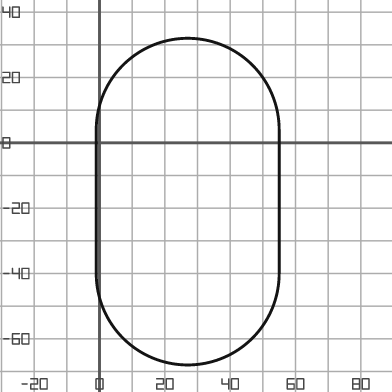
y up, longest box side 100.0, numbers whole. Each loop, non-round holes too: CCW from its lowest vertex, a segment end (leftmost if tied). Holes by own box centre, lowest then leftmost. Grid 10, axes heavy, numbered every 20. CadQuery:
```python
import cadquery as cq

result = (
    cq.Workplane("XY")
    .moveTo(-1.0, -40.0)
    .threePointArc((27.0, -68.0), (55.0, -40.0))
    .lineTo(55.0, 4.0)
    .threePointArc((27.0, 32.0), (-1.0, 4.0))
    .close()
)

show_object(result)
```